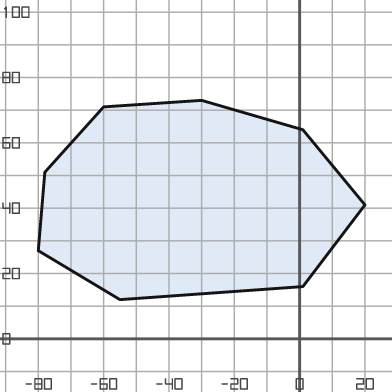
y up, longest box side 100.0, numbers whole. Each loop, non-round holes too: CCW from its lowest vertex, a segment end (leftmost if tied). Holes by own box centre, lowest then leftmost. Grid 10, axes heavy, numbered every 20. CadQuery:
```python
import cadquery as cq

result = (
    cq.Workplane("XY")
    .moveTo(-55.0, 12.0)
    .lineTo(1.0, 16.0)
    .lineTo(20.0, 41.0)
    .lineTo(1.0, 64.0)
    .lineTo(-30.0, 73.0)
    .lineTo(-60.0, 71.0)
    .lineTo(-78.0, 51.0)
    .lineTo(-80.0, 27.0)
    .close()
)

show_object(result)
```